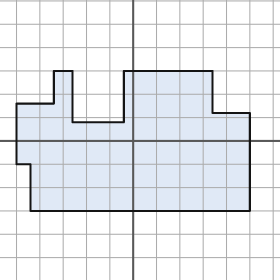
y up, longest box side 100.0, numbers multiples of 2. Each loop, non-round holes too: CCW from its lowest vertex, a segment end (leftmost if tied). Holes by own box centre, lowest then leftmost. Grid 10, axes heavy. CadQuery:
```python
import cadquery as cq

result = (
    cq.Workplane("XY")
    .moveTo(-44.0, -30.0)
    .lineTo(50.0, -30.0)
    .lineTo(50.0, 12.0)
    .lineTo(34.0, 12.0)
    .lineTo(34.0, 30.0)
    .lineTo(-4.0, 30.0)
    .lineTo(-4.0, 8.0)
    .lineTo(-26.0, 8.0)
    .lineTo(-26.0, 30.0)
    .lineTo(-34.0, 30.0)
    .lineTo(-34.0, 16.0)
    .lineTo(-50.0, 16.0)
    .lineTo(-50.0, -10.0)
    .lineTo(-44.0, -10.0)
    .close()
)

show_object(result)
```